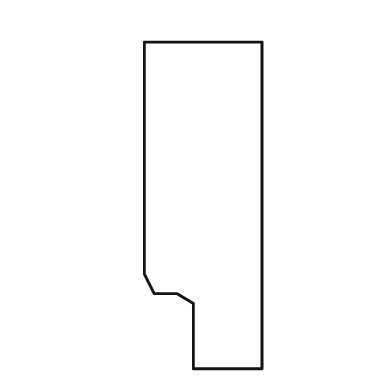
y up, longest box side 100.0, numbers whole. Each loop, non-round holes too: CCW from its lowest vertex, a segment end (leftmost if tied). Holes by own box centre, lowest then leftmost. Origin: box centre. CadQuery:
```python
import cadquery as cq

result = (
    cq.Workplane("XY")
    .moveTo(-3.0, -50.0)
    .lineTo(18.0, -50.0)
    .lineTo(18.0, 50.0)
    .lineTo(-18.0, 50.0)
    .lineTo(-18.0, -21.0)
    .lineTo(-15.0, -27.0)
    .lineTo(-8.0, -27.0)
    .lineTo(-3.0, -30.0)
    .close()
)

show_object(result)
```